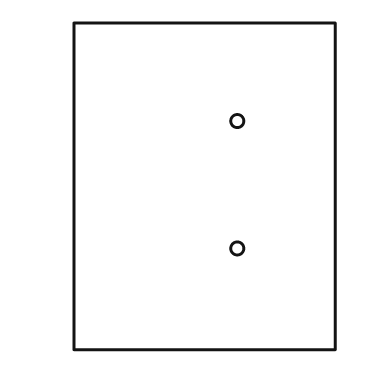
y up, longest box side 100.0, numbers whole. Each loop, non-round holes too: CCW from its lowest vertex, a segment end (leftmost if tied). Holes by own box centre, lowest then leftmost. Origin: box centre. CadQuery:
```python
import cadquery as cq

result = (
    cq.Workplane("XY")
    .moveTo(-40.0, -50.0)
    .lineTo(40.0, -50.0)
    .lineTo(40.0, 50.0)
    .lineTo(-40.0, 50.0)
    .close()
    .moveTo(10.0, -19.0)
    .circle(2.0)
    .moveTo(10.0, 20.0)
    .circle(2.0)
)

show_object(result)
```